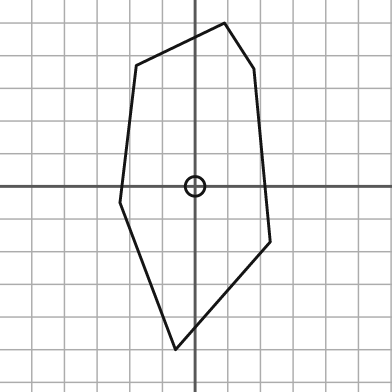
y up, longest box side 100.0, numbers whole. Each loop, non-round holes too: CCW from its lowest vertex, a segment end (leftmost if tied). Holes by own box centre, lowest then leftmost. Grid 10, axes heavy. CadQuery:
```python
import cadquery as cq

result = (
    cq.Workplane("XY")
    .moveTo(-6.0, -50.0)
    .lineTo(23.0, -17.0)
    .lineTo(18.0, 36.0)
    .lineTo(9.0, 50.0)
    .lineTo(-18.0, 37.0)
    .lineTo(-23.0, -5.0)
    .close()
    .moveTo(0.0, 0.0)
    .circle(3.0)
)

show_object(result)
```